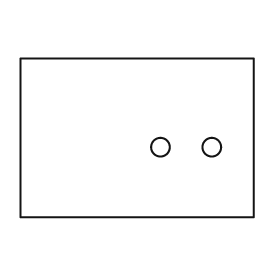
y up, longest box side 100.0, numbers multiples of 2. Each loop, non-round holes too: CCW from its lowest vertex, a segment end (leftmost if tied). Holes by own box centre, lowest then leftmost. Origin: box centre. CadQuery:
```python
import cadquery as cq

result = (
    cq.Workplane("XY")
    .moveTo(-50.0, -34.0)
    .lineTo(50.0, -34.0)
    .lineTo(50.0, 34.0)
    .lineTo(-50.0, 34.0)
    .close()
    .moveTo(10.0, -4.0)
    .circle(4.0)
    .moveTo(32.0, -4.0)
    .circle(4.0)
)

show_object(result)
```